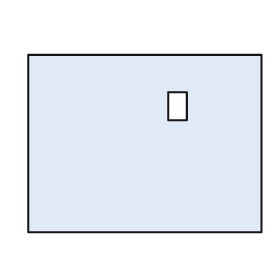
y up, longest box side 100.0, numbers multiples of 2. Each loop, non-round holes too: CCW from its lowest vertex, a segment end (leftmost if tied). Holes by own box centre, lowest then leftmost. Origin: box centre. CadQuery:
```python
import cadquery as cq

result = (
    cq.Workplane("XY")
    .moveTo(-50.0, -38.0)
    .lineTo(50.0, -38.0)
    .lineTo(50.0, 38.0)
    .lineTo(-50.0, 38.0)
    .close()
    .moveTo(10.0, 10.0)
    .lineTo(18.0, 10.0)
    .lineTo(18.0, 22.0)
    .lineTo(10.0, 22.0)
    .close()
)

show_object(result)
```